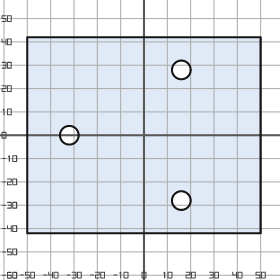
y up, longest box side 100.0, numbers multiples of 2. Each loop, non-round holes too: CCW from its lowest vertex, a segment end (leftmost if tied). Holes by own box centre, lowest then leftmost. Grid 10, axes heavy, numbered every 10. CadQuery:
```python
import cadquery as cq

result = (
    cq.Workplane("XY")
    .moveTo(-50.0, -42.0)
    .lineTo(50.0, -42.0)
    .lineTo(50.0, 42.0)
    .lineTo(-50.0, 42.0)
    .close()
    .moveTo(16.0, -28.0)
    .circle(4.0)
    .moveTo(-32.0, 0.0)
    .circle(4.0)
    .moveTo(16.0, 28.0)
    .circle(4.0)
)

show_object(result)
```